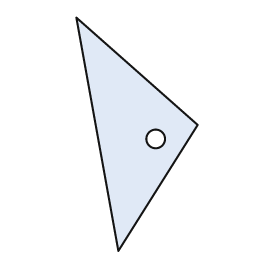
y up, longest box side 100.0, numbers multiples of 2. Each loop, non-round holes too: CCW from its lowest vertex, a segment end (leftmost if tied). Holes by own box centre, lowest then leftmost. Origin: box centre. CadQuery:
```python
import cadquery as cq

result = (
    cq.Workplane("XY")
    .moveTo(-8.0, -50.0)
    .lineTo(26.0, 4.0)
    .lineTo(-26.0, 50.0)
    .close()
    .moveTo(8.0, -2.0)
    .circle(4.0)
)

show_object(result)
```